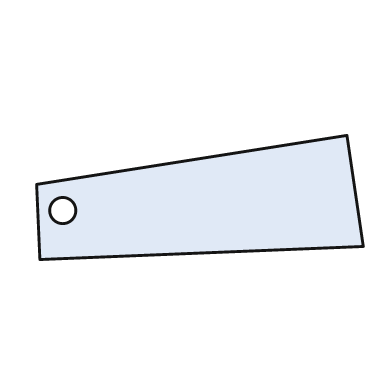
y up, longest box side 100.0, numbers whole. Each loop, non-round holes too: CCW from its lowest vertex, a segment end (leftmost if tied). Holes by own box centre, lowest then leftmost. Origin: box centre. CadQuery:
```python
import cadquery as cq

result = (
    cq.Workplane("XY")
    .moveTo(-49.0, -19.0)
    .lineTo(50.0, -15.0)
    .lineTo(45.0, 19.0)
    .lineTo(-50.0, 4.0)
    .close()
    .moveTo(-42.0, -4.0)
    .circle(4.0)
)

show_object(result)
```